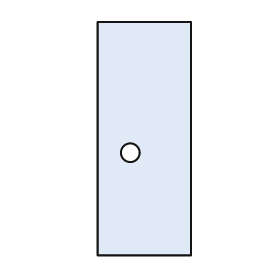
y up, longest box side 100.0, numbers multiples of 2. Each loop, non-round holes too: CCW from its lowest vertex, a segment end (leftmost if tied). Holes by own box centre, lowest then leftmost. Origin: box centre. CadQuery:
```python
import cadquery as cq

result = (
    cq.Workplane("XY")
    .moveTo(-20.0, -50.0)
    .lineTo(20.0, -50.0)
    .lineTo(20.0, 50.0)
    .lineTo(-20.0, 50.0)
    .close()
    .moveTo(-6.0, -6.0)
    .circle(4.0)
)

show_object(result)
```